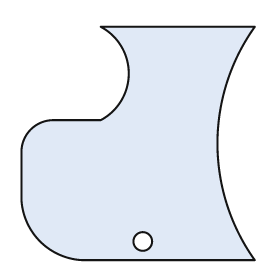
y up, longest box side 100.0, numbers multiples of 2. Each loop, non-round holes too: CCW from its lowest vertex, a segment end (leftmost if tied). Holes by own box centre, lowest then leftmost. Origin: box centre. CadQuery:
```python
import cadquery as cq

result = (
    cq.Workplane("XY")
    .moveTo(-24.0, -50.0)
    .lineTo(50.0, -50.0)
    .threePointArc((34.0, 0.0), (50.0, 50.0))
    .lineTo(-16.0, 50.0)
    .threePointArc((-4.0, 30.0), (-16.0, 10.0))
    .lineTo(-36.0, 10.0)
    .threePointArc((-46.0, 6.0), (-50.0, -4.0))
    .lineTo(-50.0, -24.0)
    .threePointArc((-42.0, -42.0), (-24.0, -50.0))
    .close()
    .moveTo(2.0, -42.0)
    .circle(4.0)
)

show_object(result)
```